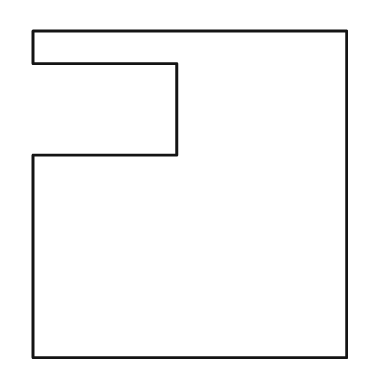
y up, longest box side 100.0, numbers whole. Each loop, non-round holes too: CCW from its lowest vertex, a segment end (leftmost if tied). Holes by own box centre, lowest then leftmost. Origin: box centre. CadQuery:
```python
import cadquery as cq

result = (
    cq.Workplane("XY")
    .moveTo(-48.0, -50.0)
    .lineTo(48.0, -50.0)
    .lineTo(48.0, 50.0)
    .lineTo(-48.0, 50.0)
    .lineTo(-48.0, 40.0)
    .lineTo(-4.0, 40.0)
    .lineTo(-4.0, 12.0)
    .lineTo(-48.0, 12.0)
    .close()
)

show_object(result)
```